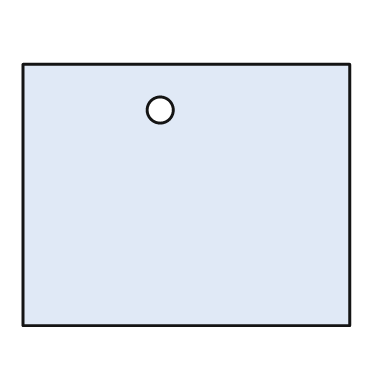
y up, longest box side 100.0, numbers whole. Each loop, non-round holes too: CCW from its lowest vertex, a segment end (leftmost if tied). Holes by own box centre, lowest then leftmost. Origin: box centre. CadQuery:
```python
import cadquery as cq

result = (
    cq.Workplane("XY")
    .moveTo(-50.0, -40.0)
    .lineTo(50.0, -40.0)
    .lineTo(50.0, 40.0)
    .lineTo(-50.0, 40.0)
    .close()
    .moveTo(-8.0, 26.0)
    .circle(4.0)
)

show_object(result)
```